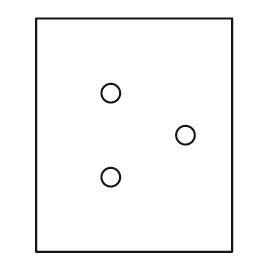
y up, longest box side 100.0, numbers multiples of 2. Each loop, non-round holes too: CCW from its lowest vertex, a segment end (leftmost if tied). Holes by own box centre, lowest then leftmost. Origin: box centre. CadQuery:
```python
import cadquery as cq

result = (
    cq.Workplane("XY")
    .moveTo(-42.0, -50.0)
    .lineTo(42.0, -50.0)
    .lineTo(42.0, 50.0)
    .lineTo(-42.0, 50.0)
    .close()
    .moveTo(-10.0, -18.0)
    .circle(4.0)
    .moveTo(22.0, 0.0)
    .circle(4.0)
    .moveTo(-10.0, 18.0)
    .circle(4.0)
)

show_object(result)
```